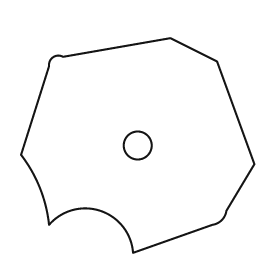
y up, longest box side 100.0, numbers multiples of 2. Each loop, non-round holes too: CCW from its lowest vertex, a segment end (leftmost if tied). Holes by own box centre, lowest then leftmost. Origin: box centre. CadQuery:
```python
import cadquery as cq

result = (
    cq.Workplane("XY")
    .moveTo(-2.0, -46.0)
    .lineTo(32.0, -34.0)
    .threePointArc((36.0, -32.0), (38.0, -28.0))
    .lineTo(50.0, -8.0)
    .lineTo(34.0, 36.0)
    .lineTo(14.0, 46.0)
    .lineTo(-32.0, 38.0)
    .threePointArc((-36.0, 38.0), (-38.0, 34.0))
    .lineTo(-50.0, -4.0)
    .threePointArc((-42.0, -18.0), (-38.0, -34.0))
    .threePointArc((-16.0, -28.0), (-2.0, -46.0))
    .close()
    .moveTo(0.0, 0.0)
    .circle(6.0)
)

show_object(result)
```